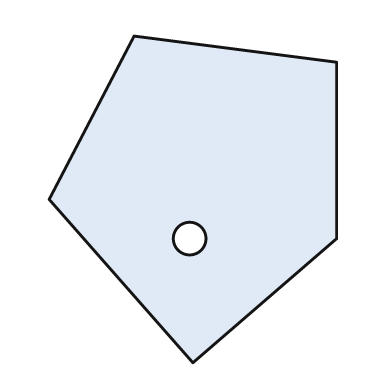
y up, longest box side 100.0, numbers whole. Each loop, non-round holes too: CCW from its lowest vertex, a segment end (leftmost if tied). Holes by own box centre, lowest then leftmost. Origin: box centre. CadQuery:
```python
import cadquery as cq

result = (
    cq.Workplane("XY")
    .moveTo(0.0, -50.0)
    .lineTo(44.0, -12.0)
    .lineTo(44.0, 42.0)
    .lineTo(-18.0, 50.0)
    .lineTo(-44.0, 0.0)
    .close()
    .moveTo(-1.0, -12.0)
    .circle(5.0)
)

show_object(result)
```